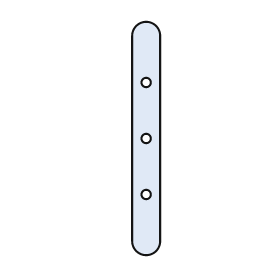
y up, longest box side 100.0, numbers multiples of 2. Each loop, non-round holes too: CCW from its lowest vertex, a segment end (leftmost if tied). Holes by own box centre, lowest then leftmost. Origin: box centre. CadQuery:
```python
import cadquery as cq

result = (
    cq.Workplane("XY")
    .moveTo(-6.0, -44.0)
    .threePointArc((0.0, -50.0), (6.0, -44.0))
    .lineTo(6.0, 44.0)
    .threePointArc((0.0, 50.0), (-6.0, 44.0))
    .close()
    .moveTo(0.0, -24.0)
    .circle(2.0)
    .moveTo(0.0, 0.0)
    .circle(2.0)
    .moveTo(0.0, 24.0)
    .circle(2.0)
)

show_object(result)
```